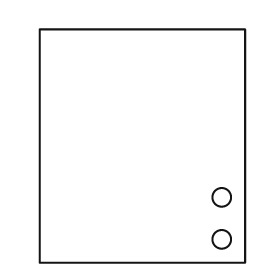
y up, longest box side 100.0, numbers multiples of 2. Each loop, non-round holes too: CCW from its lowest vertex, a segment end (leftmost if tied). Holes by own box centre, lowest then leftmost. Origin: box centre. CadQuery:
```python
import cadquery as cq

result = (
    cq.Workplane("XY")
    .moveTo(-44.0, -50.0)
    .lineTo(44.0, -50.0)
    .lineTo(44.0, 50.0)
    .lineTo(-44.0, 50.0)
    .close()
    .moveTo(34.0, -40.0)
    .circle(4.0)
    .moveTo(34.0, -22.0)
    .circle(4.0)
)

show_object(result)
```